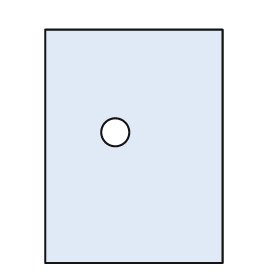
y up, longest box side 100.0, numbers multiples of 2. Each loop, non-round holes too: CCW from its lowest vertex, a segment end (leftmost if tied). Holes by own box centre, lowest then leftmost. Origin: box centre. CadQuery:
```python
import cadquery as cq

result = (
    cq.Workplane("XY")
    .moveTo(-38.0, -50.0)
    .lineTo(38.0, -50.0)
    .lineTo(38.0, 50.0)
    .lineTo(-38.0, 50.0)
    .close()
    .moveTo(-8.0, 6.0)
    .circle(6.0)
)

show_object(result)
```